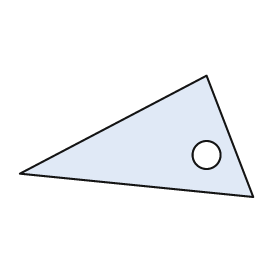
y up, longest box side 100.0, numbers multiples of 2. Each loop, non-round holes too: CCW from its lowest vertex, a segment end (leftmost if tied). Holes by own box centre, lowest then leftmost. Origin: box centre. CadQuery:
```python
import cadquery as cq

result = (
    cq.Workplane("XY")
    .moveTo(50.0, -26.0)
    .lineTo(30.0, 26.0)
    .lineTo(-50.0, -16.0)
    .close()
    .moveTo(30.0, -8.0)
    .circle(6.0)
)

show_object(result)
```